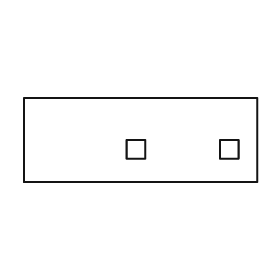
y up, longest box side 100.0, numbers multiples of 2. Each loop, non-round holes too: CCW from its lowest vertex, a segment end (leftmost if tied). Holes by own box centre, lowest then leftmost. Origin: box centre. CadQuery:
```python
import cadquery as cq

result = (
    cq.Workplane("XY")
    .moveTo(-50.0, -18.0)
    .lineTo(50.0, -18.0)
    .lineTo(50.0, 18.0)
    .lineTo(-50.0, 18.0)
    .close()
    .moveTo(-6.0, -8.0)
    .lineTo(2.0, -8.0)
    .lineTo(2.0, 0.0)
    .lineTo(-6.0, 0.0)
    .close()
    .moveTo(34.0, -8.0)
    .lineTo(42.0, -8.0)
    .lineTo(42.0, 0.0)
    .lineTo(34.0, 0.0)
    .close()
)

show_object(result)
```